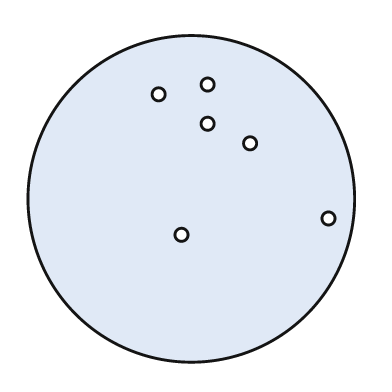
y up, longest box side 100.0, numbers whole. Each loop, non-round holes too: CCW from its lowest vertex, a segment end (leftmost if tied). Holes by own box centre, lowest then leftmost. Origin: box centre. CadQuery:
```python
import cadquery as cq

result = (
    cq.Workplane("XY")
    .moveTo(0.0, 0.0)
    .circle(50.0)
    .moveTo(-3.0, -11.0)
    .circle(2.0)
    .moveTo(42.0, -6.0)
    .circle(2.0)
    .moveTo(18.0, 17.0)
    .circle(2.0)
    .moveTo(5.0, 23.0)
    .circle(2.0)
    .moveTo(-10.0, 32.0)
    .circle(2.0)
    .moveTo(5.0, 35.0)
    .circle(2.0)
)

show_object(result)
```